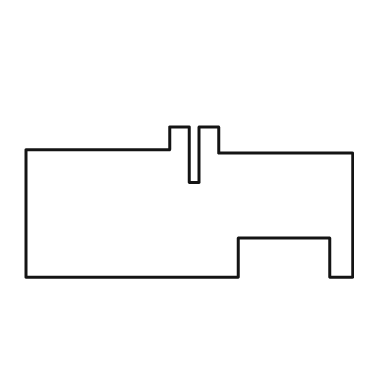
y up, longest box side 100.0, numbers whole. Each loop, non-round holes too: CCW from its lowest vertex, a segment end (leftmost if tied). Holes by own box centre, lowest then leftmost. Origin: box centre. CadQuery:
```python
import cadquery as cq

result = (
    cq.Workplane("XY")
    .moveTo(-50.0, -23.0)
    .lineTo(15.0, -23.0)
    .lineTo(15.0, -11.0)
    .lineTo(43.0, -11.0)
    .lineTo(43.0, -23.0)
    .lineTo(50.0, -23.0)
    .lineTo(50.0, 15.0)
    .lineTo(9.0, 15.0)
    .lineTo(9.0, 23.0)
    .lineTo(3.0, 23.0)
    .lineTo(3.0, 6.0)
    .lineTo(0.0, 6.0)
    .lineTo(0.0, 23.0)
    .lineTo(-6.0, 23.0)
    .lineTo(-6.0, 16.0)
    .lineTo(-50.0, 16.0)
    .close()
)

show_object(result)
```